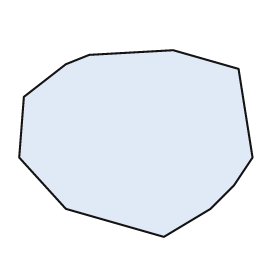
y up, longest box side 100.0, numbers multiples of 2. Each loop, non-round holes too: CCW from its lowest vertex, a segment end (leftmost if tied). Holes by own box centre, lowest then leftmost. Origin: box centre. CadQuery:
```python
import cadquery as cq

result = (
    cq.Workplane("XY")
    .moveTo(12.0, -40.0)
    .lineTo(32.0, -28.0)
    .lineTo(42.0, -18.0)
    .lineTo(50.0, -6.0)
    .lineTo(44.0, 32.0)
    .lineTo(16.0, 40.0)
    .lineTo(-20.0, 38.0)
    .lineTo(-30.0, 34.0)
    .lineTo(-48.0, 20.0)
    .lineTo(-50.0, -6.0)
    .lineTo(-30.0, -28.0)
    .close()
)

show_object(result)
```